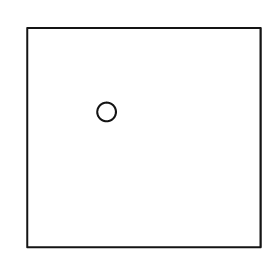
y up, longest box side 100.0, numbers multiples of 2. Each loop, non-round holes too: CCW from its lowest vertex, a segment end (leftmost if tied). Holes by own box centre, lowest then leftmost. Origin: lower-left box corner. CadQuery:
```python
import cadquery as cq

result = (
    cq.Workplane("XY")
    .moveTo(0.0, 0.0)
    .lineTo(100.0, 0.0)
    .lineTo(100.0, 94.0)
    .lineTo(0.0, 94.0)
    .close()
    .moveTo(34.0, 58.0)
    .circle(4.0)
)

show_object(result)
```